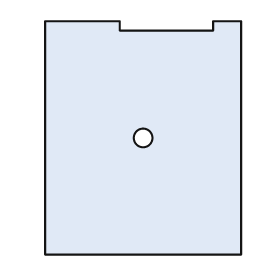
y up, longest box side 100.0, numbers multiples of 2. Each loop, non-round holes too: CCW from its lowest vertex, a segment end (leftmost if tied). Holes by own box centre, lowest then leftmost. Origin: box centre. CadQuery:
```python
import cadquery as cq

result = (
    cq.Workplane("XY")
    .moveTo(-42.0, -50.0)
    .lineTo(42.0, -50.0)
    .lineTo(42.0, 50.0)
    .lineTo(30.0, 50.0)
    .lineTo(30.0, 46.0)
    .lineTo(-10.0, 46.0)
    .lineTo(-10.0, 50.0)
    .lineTo(-42.0, 50.0)
    .close()
    .moveTo(0.0, 0.0)
    .circle(4.0)
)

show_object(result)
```